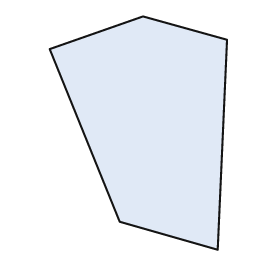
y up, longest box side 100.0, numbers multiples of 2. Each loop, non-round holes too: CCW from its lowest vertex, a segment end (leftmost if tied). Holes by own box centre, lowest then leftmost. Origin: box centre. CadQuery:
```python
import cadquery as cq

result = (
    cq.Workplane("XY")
    .moveTo(34.0, -50.0)
    .lineTo(38.0, 40.0)
    .lineTo(2.0, 50.0)
    .lineTo(-38.0, 36.0)
    .lineTo(-8.0, -38.0)
    .close()
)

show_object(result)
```